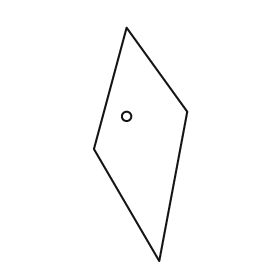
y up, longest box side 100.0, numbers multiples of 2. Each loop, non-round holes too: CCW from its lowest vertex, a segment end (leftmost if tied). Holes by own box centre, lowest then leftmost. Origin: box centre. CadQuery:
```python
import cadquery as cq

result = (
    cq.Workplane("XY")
    .moveTo(8.0, -50.0)
    .lineTo(20.0, 14.0)
    .lineTo(-6.0, 50.0)
    .lineTo(-20.0, -2.0)
    .close()
    .moveTo(-6.0, 12.0)
    .circle(2.0)
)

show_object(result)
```